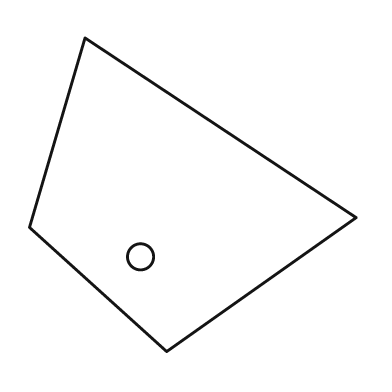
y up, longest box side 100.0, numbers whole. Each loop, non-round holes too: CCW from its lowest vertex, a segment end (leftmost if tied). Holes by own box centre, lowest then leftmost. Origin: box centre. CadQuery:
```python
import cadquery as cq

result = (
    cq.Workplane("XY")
    .moveTo(-8.0, -48.0)
    .lineTo(50.0, -7.0)
    .lineTo(-33.0, 48.0)
    .lineTo(-50.0, -10.0)
    .close()
    .moveTo(-16.0, -19.0)
    .circle(4.0)
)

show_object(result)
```